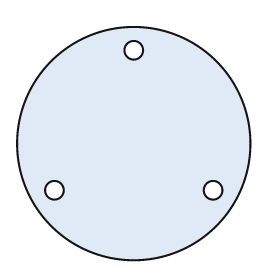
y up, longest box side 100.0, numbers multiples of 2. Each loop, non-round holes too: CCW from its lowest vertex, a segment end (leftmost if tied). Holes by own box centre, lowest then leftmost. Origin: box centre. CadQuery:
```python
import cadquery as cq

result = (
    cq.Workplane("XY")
    .moveTo(0.0, 0.0)
    .circle(50.0)
    .moveTo(-34.0, -20.0)
    .circle(4.0)
    .moveTo(34.0, -20.0)
    .circle(4.0)
    .moveTo(0.0, 40.0)
    .circle(4.0)
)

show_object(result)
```